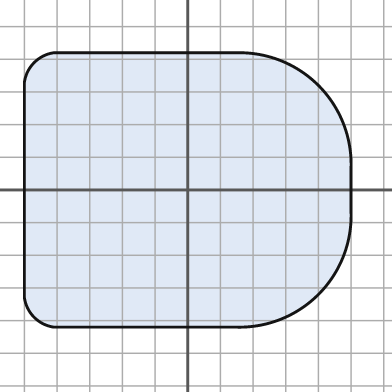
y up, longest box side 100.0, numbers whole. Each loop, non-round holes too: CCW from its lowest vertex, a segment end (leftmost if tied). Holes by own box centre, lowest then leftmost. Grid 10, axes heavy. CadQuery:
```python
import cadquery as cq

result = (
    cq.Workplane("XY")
    .moveTo(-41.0, -42.0)
    .lineTo(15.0, -42.0)
    .threePointArc((40.0, -32.0), (50.0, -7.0))
    .lineTo(50.0, 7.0)
    .threePointArc((40.0, 32.0), (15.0, 42.0))
    .lineTo(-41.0, 42.0)
    .threePointArc((-47.0, 39.0), (-50.0, 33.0))
    .lineTo(-50.0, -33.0)
    .threePointArc((-47.0, -39.0), (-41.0, -42.0))
    .close()
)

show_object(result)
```